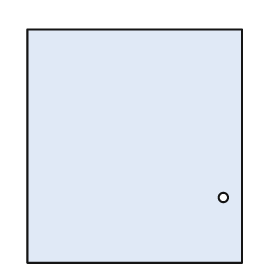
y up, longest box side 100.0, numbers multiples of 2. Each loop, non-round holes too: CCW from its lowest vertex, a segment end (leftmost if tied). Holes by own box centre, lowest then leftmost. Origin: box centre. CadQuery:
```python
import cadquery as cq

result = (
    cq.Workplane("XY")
    .moveTo(-46.0, -50.0)
    .lineTo(46.0, -50.0)
    .lineTo(46.0, 50.0)
    .lineTo(-46.0, 50.0)
    .close()
    .moveTo(38.0, -22.0)
    .circle(2.0)
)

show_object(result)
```